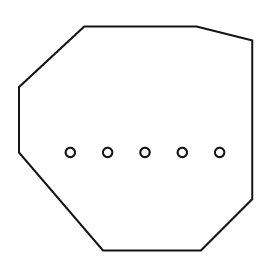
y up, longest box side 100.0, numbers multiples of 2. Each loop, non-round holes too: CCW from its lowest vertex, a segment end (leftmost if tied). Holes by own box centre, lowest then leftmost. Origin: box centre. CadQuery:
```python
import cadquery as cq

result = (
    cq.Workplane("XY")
    .moveTo(-14.0, -48.0)
    .lineTo(28.0, -48.0)
    .lineTo(50.0, -26.0)
    .lineTo(50.0, 42.0)
    .lineTo(26.0, 48.0)
    .lineTo(-22.0, 48.0)
    .lineTo(-50.0, 22.0)
    .lineTo(-50.0, -6.0)
    .close()
    .moveTo(-28.0, -6.0)
    .circle(2.0)
    .moveTo(-12.0, -6.0)
    .circle(2.0)
    .moveTo(4.0, -6.0)
    .circle(2.0)
    .moveTo(20.0, -6.0)
    .circle(2.0)
    .moveTo(36.0, -6.0)
    .circle(2.0)
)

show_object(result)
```